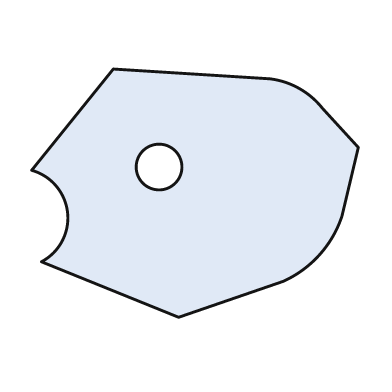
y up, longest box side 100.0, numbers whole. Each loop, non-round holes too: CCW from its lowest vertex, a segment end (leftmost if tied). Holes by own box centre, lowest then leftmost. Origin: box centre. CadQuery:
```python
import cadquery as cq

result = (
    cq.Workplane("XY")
    .moveTo(-5.0, -38.0)
    .lineTo(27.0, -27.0)
    .threePointArc((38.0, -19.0), (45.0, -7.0))
    .lineTo(50.0, 14.0)
    .lineTo(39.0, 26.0)
    .threePointArc((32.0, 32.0), (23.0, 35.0))
    .lineTo(-25.0, 38.0)
    .lineTo(-50.0, 7.0)
    .threePointArc((-39.0, -6.0), (-47.0, -21.0))
    .close()
    .moveTo(-11.0, 8.0)
    .circle(7.0)
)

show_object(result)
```